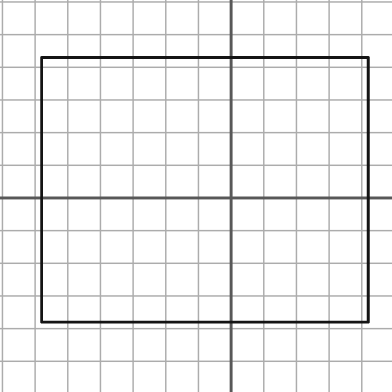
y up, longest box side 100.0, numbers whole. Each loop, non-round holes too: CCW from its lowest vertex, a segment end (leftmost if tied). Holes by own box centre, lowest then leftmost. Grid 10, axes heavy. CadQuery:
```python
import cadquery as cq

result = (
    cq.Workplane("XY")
    .moveTo(-58.0, -38.0)
    .lineTo(42.0, -38.0)
    .lineTo(42.0, 43.0)
    .lineTo(-58.0, 43.0)
    .close()
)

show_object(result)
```